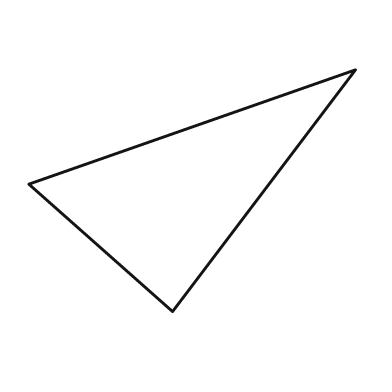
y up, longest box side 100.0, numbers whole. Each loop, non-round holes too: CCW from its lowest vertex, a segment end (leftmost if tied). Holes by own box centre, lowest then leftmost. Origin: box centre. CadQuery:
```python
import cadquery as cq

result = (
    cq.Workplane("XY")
    .moveTo(-6.0, -37.0)
    .lineTo(50.0, 37.0)
    .lineTo(-50.0, 2.0)
    .close()
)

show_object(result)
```